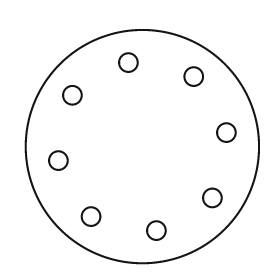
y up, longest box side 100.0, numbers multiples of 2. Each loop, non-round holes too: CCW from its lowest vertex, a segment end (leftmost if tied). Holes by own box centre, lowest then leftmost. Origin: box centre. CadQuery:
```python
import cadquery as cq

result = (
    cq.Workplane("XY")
    .moveTo(0.0, 0.0)
    .circle(50.0)
    .moveTo(6.0, -36.0)
    .circle(4.0)
    .moveTo(-22.0, -30.0)
    .circle(4.0)
    .moveTo(30.0, -22.0)
    .circle(4.0)
    .moveTo(-36.0, -6.0)
    .circle(4.0)
    .moveTo(36.0, 6.0)
    .circle(4.0)
    .moveTo(-30.0, 22.0)
    .circle(4.0)
    .moveTo(22.0, 30.0)
    .circle(4.0)
    .moveTo(-6.0, 36.0)
    .circle(4.0)
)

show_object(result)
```